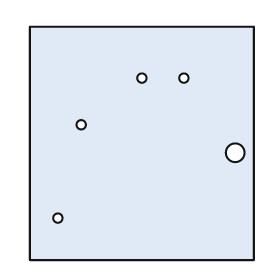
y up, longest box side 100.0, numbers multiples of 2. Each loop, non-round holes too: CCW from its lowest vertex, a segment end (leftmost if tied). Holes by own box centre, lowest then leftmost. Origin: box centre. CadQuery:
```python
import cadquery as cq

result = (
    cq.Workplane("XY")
    .moveTo(-48.0, -50.0)
    .lineTo(48.0, -50.0)
    .lineTo(48.0, 50.0)
    .lineTo(-48.0, 50.0)
    .close()
    .moveTo(-36.0, -32.0)
    .circle(2.0)
    .moveTo(40.0, -4.0)
    .circle(4.0)
    .moveTo(-26.0, 8.0)
    .circle(2.0)
    .moveTo(0.0, 28.0)
    .circle(2.0)
    .moveTo(18.0, 28.0)
    .circle(2.0)
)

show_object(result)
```